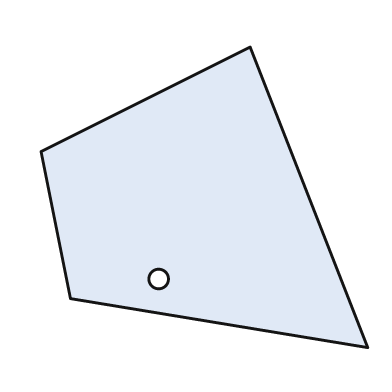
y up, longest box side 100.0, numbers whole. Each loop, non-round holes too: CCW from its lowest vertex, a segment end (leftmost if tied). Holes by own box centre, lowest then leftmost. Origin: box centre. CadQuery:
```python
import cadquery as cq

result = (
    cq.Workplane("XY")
    .moveTo(50.0, -46.0)
    .lineTo(14.0, 46.0)
    .lineTo(-50.0, 14.0)
    .lineTo(-41.0, -31.0)
    .close()
    .moveTo(-14.0, -25.0)
    .circle(3.0)
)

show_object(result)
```